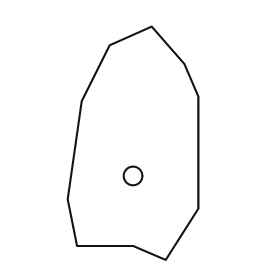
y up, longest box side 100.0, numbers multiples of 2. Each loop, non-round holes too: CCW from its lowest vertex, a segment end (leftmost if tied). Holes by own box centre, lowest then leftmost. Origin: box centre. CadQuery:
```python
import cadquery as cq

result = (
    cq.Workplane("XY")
    .moveTo(14.0, -50.0)
    .lineTo(28.0, -28.0)
    .lineTo(28.0, 20.0)
    .lineTo(22.0, 34.0)
    .lineTo(8.0, 50.0)
    .lineTo(-10.0, 42.0)
    .lineTo(-22.0, 18.0)
    .lineTo(-28.0, -24.0)
    .lineTo(-24.0, -44.0)
    .lineTo(0.0, -44.0)
    .close()
    .moveTo(0.0, -14.0)
    .circle(4.0)
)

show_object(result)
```